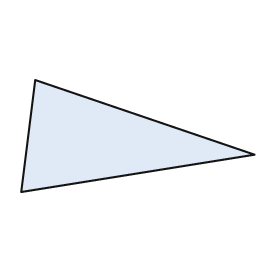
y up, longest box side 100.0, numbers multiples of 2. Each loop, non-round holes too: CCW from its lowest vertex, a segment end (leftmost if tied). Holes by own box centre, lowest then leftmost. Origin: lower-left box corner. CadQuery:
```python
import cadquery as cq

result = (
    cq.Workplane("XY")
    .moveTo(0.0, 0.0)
    .lineTo(100.0, 16.0)
    .lineTo(6.0, 48.0)
    .close()
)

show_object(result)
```